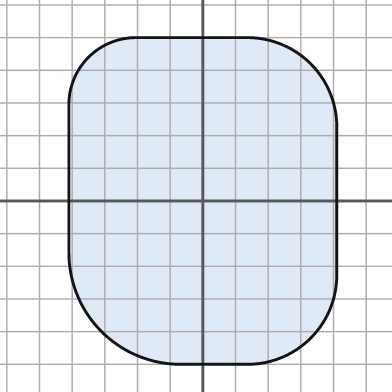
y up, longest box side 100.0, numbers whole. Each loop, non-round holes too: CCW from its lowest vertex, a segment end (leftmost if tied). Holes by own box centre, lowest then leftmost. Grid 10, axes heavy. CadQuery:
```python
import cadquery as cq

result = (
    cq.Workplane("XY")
    .moveTo(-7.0, -50.0)
    .lineTo(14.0, -50.0)
    .threePointArc((33.0, -42.0), (41.0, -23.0))
    .lineTo(41.0, 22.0)
    .threePointArc((33.0, 42.0), (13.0, 50.0))
    .lineTo(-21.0, 50.0)
    .threePointArc((-35.0, 44.0), (-41.0, 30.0))
    .lineTo(-41.0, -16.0)
    .threePointArc((-31.0, -40.0), (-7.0, -50.0))
    .close()
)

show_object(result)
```